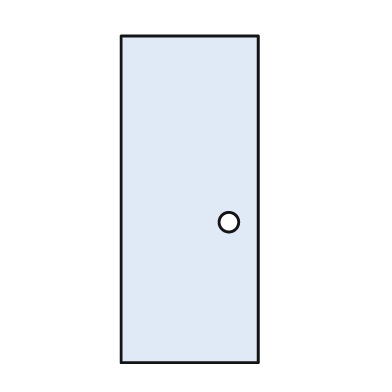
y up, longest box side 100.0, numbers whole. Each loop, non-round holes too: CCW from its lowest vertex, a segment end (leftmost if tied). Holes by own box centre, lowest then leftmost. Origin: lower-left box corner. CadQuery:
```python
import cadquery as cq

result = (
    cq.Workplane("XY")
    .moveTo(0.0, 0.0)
    .lineTo(42.0, 0.0)
    .lineTo(42.0, 100.0)
    .lineTo(0.0, 100.0)
    .close()
    .moveTo(33.0, 43.0)
    .circle(3.0)
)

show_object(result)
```